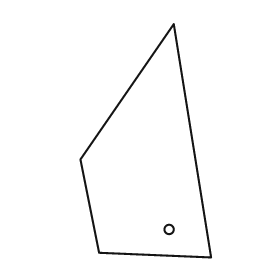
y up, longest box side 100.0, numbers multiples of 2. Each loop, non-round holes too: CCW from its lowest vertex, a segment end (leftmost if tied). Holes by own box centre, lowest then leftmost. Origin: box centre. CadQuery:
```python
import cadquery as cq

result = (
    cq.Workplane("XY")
    .moveTo(28.0, -50.0)
    .lineTo(12.0, 50.0)
    .lineTo(-28.0, -8.0)
    .lineTo(-20.0, -48.0)
    .close()
    .moveTo(10.0, -38.0)
    .circle(2.0)
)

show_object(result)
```